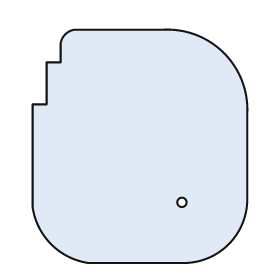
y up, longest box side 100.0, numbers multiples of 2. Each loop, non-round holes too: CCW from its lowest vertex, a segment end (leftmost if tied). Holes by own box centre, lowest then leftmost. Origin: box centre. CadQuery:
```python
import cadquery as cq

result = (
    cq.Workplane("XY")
    .moveTo(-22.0, -50.0)
    .lineTo(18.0, -50.0)
    .threePointArc((38.0, -42.0), (46.0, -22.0))
    .lineTo(46.0, 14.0)
    .threePointArc((36.0, 40.0), (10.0, 50.0))
    .lineTo(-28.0, 50.0)
    .threePointArc((-32.0, 48.0), (-34.0, 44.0))
    .lineTo(-34.0, 36.0)
    .lineTo(-40.0, 36.0)
    .lineTo(-40.0, 18.0)
    .lineTo(-46.0, 18.0)
    .lineTo(-46.0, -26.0)
    .threePointArc((-38.0, -42.0), (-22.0, -50.0))
    .close()
    .moveTo(18.0, -24.0)
    .circle(2.0)
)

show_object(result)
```